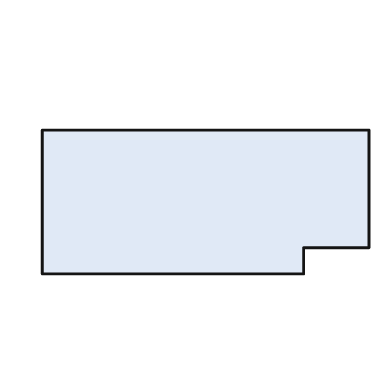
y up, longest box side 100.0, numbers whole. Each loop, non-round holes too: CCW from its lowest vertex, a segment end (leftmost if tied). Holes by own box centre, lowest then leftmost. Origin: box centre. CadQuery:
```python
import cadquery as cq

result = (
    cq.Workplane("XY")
    .moveTo(-50.0, -22.0)
    .lineTo(30.0, -22.0)
    .lineTo(30.0, -14.0)
    .lineTo(50.0, -14.0)
    .lineTo(50.0, 22.0)
    .lineTo(-50.0, 22.0)
    .close()
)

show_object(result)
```